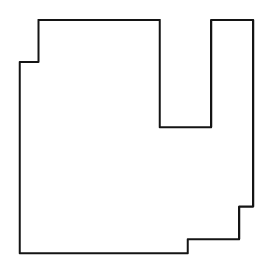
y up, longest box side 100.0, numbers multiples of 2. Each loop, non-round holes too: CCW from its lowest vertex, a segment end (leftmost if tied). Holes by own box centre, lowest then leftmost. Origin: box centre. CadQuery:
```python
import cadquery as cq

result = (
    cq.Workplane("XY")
    .moveTo(-50.0, -50.0)
    .lineTo(22.0, -50.0)
    .lineTo(22.0, -44.0)
    .lineTo(44.0, -44.0)
    .lineTo(44.0, -30.0)
    .lineTo(50.0, -30.0)
    .lineTo(50.0, 50.0)
    .lineTo(32.0, 50.0)
    .lineTo(32.0, 4.0)
    .lineTo(10.0, 4.0)
    .lineTo(10.0, 50.0)
    .lineTo(-42.0, 50.0)
    .lineTo(-42.0, 32.0)
    .lineTo(-50.0, 32.0)
    .close()
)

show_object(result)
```